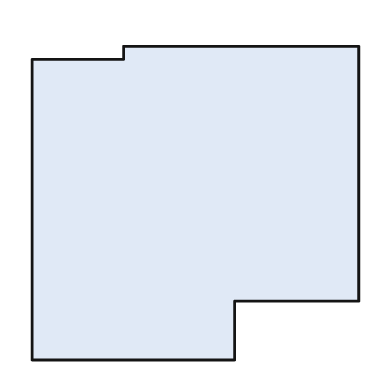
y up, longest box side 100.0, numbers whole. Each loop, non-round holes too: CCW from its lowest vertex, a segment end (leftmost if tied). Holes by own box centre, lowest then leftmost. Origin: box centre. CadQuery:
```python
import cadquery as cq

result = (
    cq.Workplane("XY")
    .moveTo(-50.0, -48.0)
    .lineTo(12.0, -48.0)
    .lineTo(12.0, -30.0)
    .lineTo(50.0, -30.0)
    .lineTo(50.0, 48.0)
    .lineTo(-22.0, 48.0)
    .lineTo(-22.0, 44.0)
    .lineTo(-50.0, 44.0)
    .close()
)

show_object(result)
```